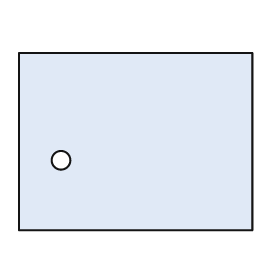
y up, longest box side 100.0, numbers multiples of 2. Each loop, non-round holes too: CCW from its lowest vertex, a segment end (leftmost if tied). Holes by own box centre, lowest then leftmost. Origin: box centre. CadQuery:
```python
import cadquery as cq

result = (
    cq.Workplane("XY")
    .moveTo(-50.0, -38.0)
    .lineTo(50.0, -38.0)
    .lineTo(50.0, 38.0)
    .lineTo(-50.0, 38.0)
    .close()
    .moveTo(-32.0, -8.0)
    .circle(4.0)
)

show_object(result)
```